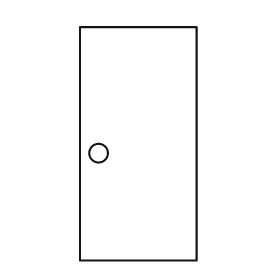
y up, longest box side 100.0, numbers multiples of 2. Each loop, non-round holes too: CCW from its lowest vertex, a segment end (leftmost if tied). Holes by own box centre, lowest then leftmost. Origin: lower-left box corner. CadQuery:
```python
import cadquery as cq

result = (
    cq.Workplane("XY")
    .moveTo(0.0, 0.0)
    .lineTo(50.0, 0.0)
    .lineTo(50.0, 100.0)
    .lineTo(0.0, 100.0)
    .close()
    .moveTo(8.0, 46.0)
    .circle(4.0)
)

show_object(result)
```